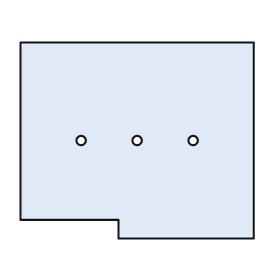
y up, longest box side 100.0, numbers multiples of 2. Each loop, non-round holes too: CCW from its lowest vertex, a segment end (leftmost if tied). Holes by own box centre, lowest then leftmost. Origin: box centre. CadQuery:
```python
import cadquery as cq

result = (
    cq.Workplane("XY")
    .moveTo(-8.0, -42.0)
    .lineTo(50.0, -42.0)
    .lineTo(50.0, 42.0)
    .lineTo(-50.0, 42.0)
    .lineTo(-50.0, -34.0)
    .lineTo(-8.0, -34.0)
    .close()
    .moveTo(-24.0, 0.0)
    .circle(2.0)
    .moveTo(0.0, 0.0)
    .circle(2.0)
    .moveTo(24.0, 0.0)
    .circle(2.0)
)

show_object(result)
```